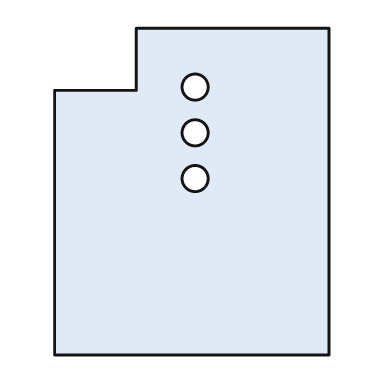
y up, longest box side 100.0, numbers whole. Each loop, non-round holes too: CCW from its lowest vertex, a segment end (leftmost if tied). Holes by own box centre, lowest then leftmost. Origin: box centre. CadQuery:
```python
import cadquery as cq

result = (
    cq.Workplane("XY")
    .moveTo(-42.0, -50.0)
    .lineTo(42.0, -50.0)
    .lineTo(42.0, 50.0)
    .lineTo(-17.0, 50.0)
    .lineTo(-17.0, 31.0)
    .lineTo(-42.0, 31.0)
    .close()
    .moveTo(1.0, 4.0)
    .circle(4.0)
    .moveTo(1.0, 18.0)
    .circle(4.0)
    .moveTo(1.0, 32.0)
    .circle(4.0)
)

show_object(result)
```